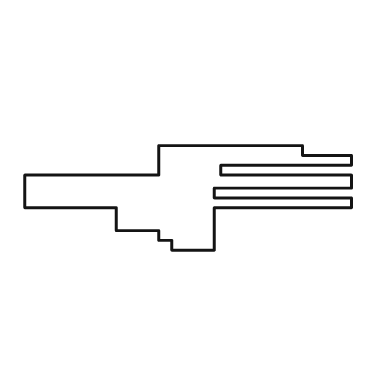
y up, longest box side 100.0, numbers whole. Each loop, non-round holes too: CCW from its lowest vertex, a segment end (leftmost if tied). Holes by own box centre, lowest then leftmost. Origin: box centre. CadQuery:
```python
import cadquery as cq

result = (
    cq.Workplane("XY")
    .moveTo(-5.0, -16.0)
    .lineTo(8.0, -16.0)
    .lineTo(8.0, -3.0)
    .lineTo(50.0, -3.0)
    .lineTo(50.0, 0.0)
    .lineTo(8.0, 0.0)
    .lineTo(8.0, 3.0)
    .lineTo(50.0, 3.0)
    .lineTo(50.0, 7.0)
    .lineTo(10.0, 7.0)
    .lineTo(10.0, 10.0)
    .lineTo(50.0, 10.0)
    .lineTo(50.0, 13.0)
    .lineTo(35.0, 13.0)
    .lineTo(35.0, 16.0)
    .lineTo(-9.0, 16.0)
    .lineTo(-9.0, 7.0)
    .lineTo(-50.0, 7.0)
    .lineTo(-50.0, -3.0)
    .lineTo(-22.0, -3.0)
    .lineTo(-22.0, -10.0)
    .lineTo(-9.0, -10.0)
    .lineTo(-9.0, -13.0)
    .lineTo(-5.0, -13.0)
    .close()
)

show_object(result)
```